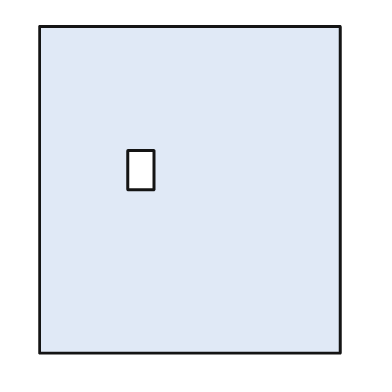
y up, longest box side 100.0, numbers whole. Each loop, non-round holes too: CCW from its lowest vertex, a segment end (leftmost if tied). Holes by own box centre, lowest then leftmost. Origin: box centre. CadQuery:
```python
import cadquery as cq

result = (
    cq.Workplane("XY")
    .moveTo(-46.0, -50.0)
    .lineTo(46.0, -50.0)
    .lineTo(46.0, 50.0)
    .lineTo(-46.0, 50.0)
    .close()
    .moveTo(-19.0, 0.0)
    .lineTo(-11.0, 0.0)
    .lineTo(-11.0, 12.0)
    .lineTo(-19.0, 12.0)
    .close()
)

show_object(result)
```